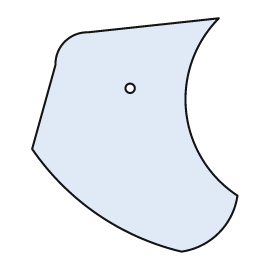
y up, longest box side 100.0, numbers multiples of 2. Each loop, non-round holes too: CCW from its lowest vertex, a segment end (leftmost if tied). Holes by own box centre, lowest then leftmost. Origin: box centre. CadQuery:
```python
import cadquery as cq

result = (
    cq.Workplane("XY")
    .moveTo(20.0, -50.0)
    .threePointArc((36.0, -42.0), (44.0, -26.0))
    .threePointArc((22.0, 10.0), (36.0, 50.0))
    .lineTo(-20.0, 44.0)
    .threePointArc((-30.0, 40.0), (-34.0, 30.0))
    .lineTo(-44.0, -6.0)
    .threePointArc((-16.0, -34.0), (20.0, -50.0))
    .close()
    .moveTo(-2.0, 20.0)
    .circle(2.0)
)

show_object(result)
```